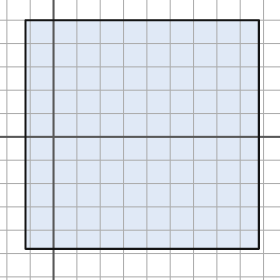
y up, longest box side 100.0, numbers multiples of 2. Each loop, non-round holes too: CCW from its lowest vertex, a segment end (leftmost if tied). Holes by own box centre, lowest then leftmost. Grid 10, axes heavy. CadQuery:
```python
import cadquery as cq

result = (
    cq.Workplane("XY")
    .moveTo(-12.0, -48.0)
    .lineTo(88.0, -48.0)
    .lineTo(88.0, 50.0)
    .lineTo(-12.0, 50.0)
    .close()
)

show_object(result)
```